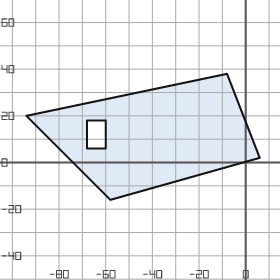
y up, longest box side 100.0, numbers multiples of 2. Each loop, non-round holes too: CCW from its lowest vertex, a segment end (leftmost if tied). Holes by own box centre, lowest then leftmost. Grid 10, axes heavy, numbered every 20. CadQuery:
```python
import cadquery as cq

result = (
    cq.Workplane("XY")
    .moveTo(-58.0, -16.0)
    .lineTo(6.0, 2.0)
    .lineTo(-8.0, 38.0)
    .lineTo(-94.0, 20.0)
    .close()
    .moveTo(-68.0, 6.0)
    .lineTo(-60.0, 6.0)
    .lineTo(-60.0, 18.0)
    .lineTo(-68.0, 18.0)
    .close()
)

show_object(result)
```